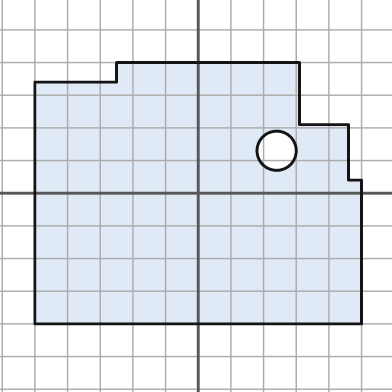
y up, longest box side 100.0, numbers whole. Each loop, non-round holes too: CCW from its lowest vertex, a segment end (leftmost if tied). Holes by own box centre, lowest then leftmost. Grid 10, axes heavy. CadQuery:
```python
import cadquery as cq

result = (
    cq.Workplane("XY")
    .moveTo(-50.0, -40.0)
    .lineTo(50.0, -40.0)
    .lineTo(50.0, 4.0)
    .lineTo(46.0, 4.0)
    .lineTo(46.0, 21.0)
    .lineTo(31.0, 21.0)
    .lineTo(31.0, 40.0)
    .lineTo(-25.0, 40.0)
    .lineTo(-25.0, 34.0)
    .lineTo(-50.0, 34.0)
    .close()
    .moveTo(24.0, 13.0)
    .circle(6.0)
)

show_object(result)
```